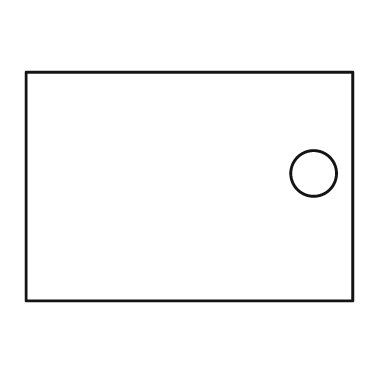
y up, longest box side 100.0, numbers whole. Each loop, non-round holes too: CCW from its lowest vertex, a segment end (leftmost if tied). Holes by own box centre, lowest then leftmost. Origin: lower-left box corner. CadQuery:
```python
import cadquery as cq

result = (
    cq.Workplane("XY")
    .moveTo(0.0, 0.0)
    .lineTo(100.0, 0.0)
    .lineTo(100.0, 70.0)
    .lineTo(0.0, 70.0)
    .close()
    .moveTo(88.0, 39.0)
    .circle(7.0)
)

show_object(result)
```